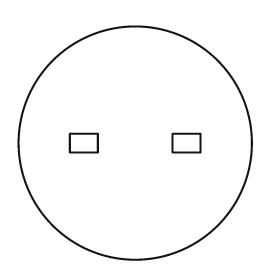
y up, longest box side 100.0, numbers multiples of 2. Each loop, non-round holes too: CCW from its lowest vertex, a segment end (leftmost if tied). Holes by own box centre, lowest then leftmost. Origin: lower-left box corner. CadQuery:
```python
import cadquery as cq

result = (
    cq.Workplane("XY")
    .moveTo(50.0, 50.0)
    .circle(50.0)
    .moveTo(22.0, 46.0)
    .lineTo(34.0, 46.0)
    .lineTo(34.0, 54.0)
    .lineTo(22.0, 54.0)
    .close()
    .moveTo(66.0, 46.0)
    .lineTo(78.0, 46.0)
    .lineTo(78.0, 54.0)
    .lineTo(66.0, 54.0)
    .close()
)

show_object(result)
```